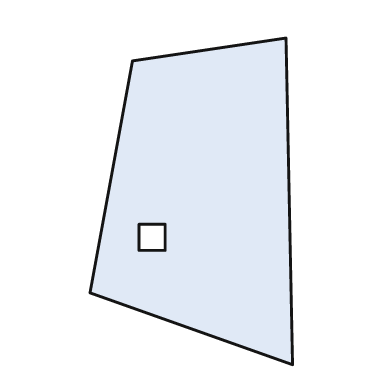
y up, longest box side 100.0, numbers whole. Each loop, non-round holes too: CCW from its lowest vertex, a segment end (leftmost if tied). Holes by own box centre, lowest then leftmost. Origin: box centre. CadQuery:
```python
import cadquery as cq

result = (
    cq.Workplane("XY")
    .moveTo(31.0, -50.0)
    .lineTo(29.0, 50.0)
    .lineTo(-18.0, 43.0)
    .lineTo(-31.0, -28.0)
    .close()
    .moveTo(-16.0, -15.0)
    .lineTo(-8.0, -15.0)
    .lineTo(-8.0, -7.0)
    .lineTo(-16.0, -7.0)
    .close()
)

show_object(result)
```